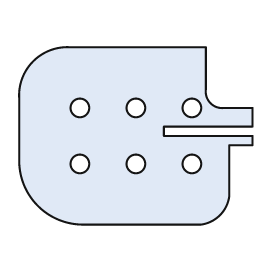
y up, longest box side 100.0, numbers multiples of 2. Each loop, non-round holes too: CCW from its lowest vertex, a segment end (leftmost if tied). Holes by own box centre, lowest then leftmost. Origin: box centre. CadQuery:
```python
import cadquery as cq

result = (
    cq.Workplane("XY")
    .moveTo(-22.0, -38.0)
    .lineTo(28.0, -38.0)
    .threePointArc((36.0, -34.0), (40.0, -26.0))
    .lineTo(40.0, -4.0)
    .lineTo(50.0, -4.0)
    .lineTo(50.0, 0.0)
    .lineTo(12.0, 0.0)
    .lineTo(12.0, 4.0)
    .lineTo(50.0, 4.0)
    .lineTo(50.0, 12.0)
    .lineTo(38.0, 12.0)
    .threePointArc((32.0, 14.0), (30.0, 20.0))
    .lineTo(30.0, 38.0)
    .lineTo(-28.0, 38.0)
    .threePointArc((-44.0, 32.0), (-50.0, 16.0))
    .lineTo(-50.0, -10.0)
    .threePointArc((-42.0, -30.0), (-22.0, -38.0))
    .close()
    .moveTo(-24.0, -12.0)
    .circle(4.0)
    .moveTo(0.0, -12.0)
    .circle(4.0)
    .moveTo(24.0, -12.0)
    .circle(4.0)
    .moveTo(-24.0, 12.0)
    .circle(4.0)
    .moveTo(0.0, 12.0)
    .circle(4.0)
    .moveTo(24.0, 12.0)
    .circle(4.0)
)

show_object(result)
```